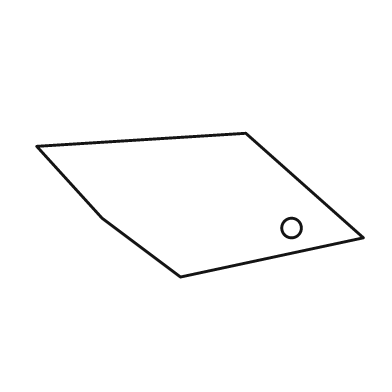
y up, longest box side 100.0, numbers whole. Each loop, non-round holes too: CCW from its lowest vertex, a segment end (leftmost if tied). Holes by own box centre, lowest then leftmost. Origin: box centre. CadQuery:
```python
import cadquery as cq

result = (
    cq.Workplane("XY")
    .moveTo(-6.0, -22.0)
    .lineTo(50.0, -10.0)
    .lineTo(14.0, 22.0)
    .lineTo(-50.0, 18.0)
    .lineTo(-30.0, -4.0)
    .close()
    .moveTo(28.0, -7.0)
    .circle(3.0)
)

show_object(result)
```